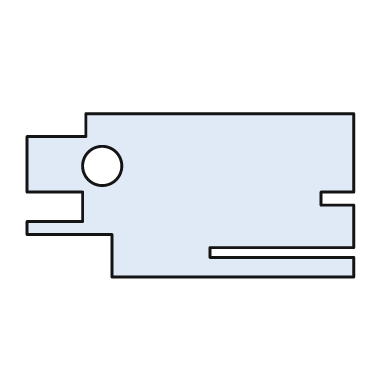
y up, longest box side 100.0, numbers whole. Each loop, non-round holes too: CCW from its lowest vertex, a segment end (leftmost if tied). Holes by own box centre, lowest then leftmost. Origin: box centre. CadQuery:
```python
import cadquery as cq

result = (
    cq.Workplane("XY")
    .moveTo(-24.0, -25.0)
    .lineTo(50.0, -25.0)
    .lineTo(50.0, -19.0)
    .lineTo(6.0, -19.0)
    .lineTo(6.0, -16.0)
    .lineTo(50.0, -16.0)
    .lineTo(50.0, -3.0)
    .lineTo(40.0, -3.0)
    .lineTo(40.0, 1.0)
    .lineTo(50.0, 1.0)
    .lineTo(50.0, 25.0)
    .lineTo(-32.0, 25.0)
    .lineTo(-32.0, 18.0)
    .lineTo(-50.0, 18.0)
    .lineTo(-50.0, 1.0)
    .lineTo(-33.0, 1.0)
    .lineTo(-33.0, -8.0)
    .lineTo(-50.0, -8.0)
    .lineTo(-50.0, -12.0)
    .lineTo(-24.0, -12.0)
    .close()
    .moveTo(-27.0, 9.0)
    .circle(6.0)
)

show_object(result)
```